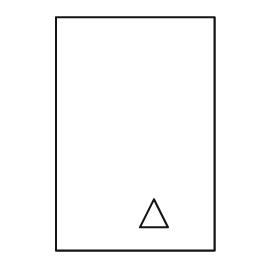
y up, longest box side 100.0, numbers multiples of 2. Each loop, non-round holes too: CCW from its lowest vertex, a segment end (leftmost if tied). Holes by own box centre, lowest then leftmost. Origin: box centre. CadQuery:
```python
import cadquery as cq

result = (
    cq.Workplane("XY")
    .moveTo(-34.0, -50.0)
    .lineTo(34.0, -50.0)
    .lineTo(34.0, 50.0)
    .lineTo(-34.0, 50.0)
    .close()
    .moveTo(2.0, -40.0)
    .lineTo(14.0, -40.0)
    .lineTo(8.0, -28.0)
    .close()
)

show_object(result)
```